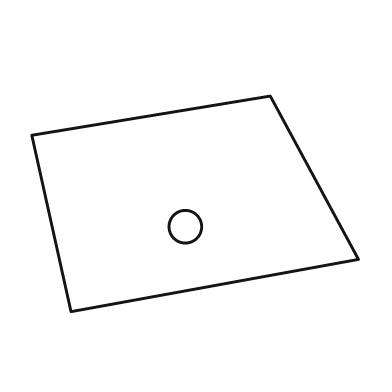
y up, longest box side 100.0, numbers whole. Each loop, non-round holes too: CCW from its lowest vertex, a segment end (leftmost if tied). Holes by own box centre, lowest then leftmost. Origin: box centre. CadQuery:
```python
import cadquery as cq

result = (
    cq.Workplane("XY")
    .moveTo(-38.0, -33.0)
    .lineTo(50.0, -17.0)
    .lineTo(23.0, 33.0)
    .lineTo(-50.0, 21.0)
    .close()
    .moveTo(-3.0, -7.0)
    .circle(5.0)
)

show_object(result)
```